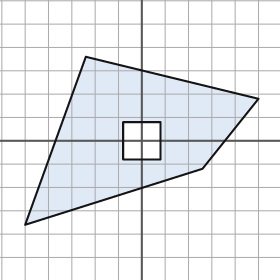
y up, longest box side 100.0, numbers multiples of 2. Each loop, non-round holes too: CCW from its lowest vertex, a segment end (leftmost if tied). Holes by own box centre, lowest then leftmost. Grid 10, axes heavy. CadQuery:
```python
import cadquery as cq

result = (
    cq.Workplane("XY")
    .moveTo(-50.0, -36.0)
    .lineTo(26.0, -12.0)
    .lineTo(50.0, 18.0)
    .lineTo(-24.0, 36.0)
    .close()
    .moveTo(-8.0, -8.0)
    .lineTo(8.0, -8.0)
    .lineTo(8.0, 8.0)
    .lineTo(-8.0, 8.0)
    .close()
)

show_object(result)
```